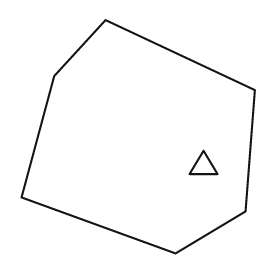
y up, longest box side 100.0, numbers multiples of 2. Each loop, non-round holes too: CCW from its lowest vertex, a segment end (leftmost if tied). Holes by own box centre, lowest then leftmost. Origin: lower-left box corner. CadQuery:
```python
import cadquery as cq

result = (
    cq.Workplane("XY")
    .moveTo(66.0, 0.0)
    .lineTo(96.0, 18.0)
    .lineTo(100.0, 70.0)
    .lineTo(36.0, 100.0)
    .lineTo(14.0, 76.0)
    .lineTo(0.0, 24.0)
    .close()
    .moveTo(72.0, 34.0)
    .lineTo(84.0, 34.0)
    .lineTo(78.0, 44.0)
    .close()
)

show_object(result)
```